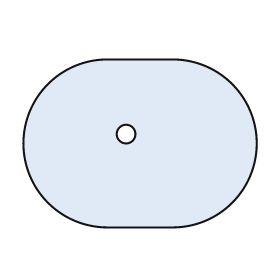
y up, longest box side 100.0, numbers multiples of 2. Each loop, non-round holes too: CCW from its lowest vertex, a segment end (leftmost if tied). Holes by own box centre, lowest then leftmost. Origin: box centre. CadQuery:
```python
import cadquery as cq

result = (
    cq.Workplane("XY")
    .moveTo(-14.0, -36.0)
    .lineTo(14.0, -36.0)
    .threePointArc((50.0, 0.0), (14.0, 36.0))
    .lineTo(-14.0, 36.0)
    .threePointArc((-50.0, 0.0), (-14.0, -36.0))
    .close()
    .moveTo(-6.0, 4.0)
    .circle(4.0)
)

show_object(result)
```